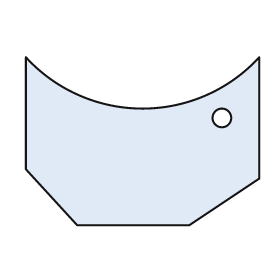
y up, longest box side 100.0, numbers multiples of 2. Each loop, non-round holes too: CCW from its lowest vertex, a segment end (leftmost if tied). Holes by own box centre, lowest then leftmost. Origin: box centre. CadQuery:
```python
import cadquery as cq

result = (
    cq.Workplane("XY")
    .moveTo(-28.0, -36.0)
    .lineTo(20.0, -36.0)
    .lineTo(50.0, -16.0)
    .lineTo(50.0, 36.0)
    .threePointArc((0.0, 14.0), (-50.0, 36.0))
    .lineTo(-50.0, -12.0)
    .close()
    .moveTo(34.0, 10.0)
    .circle(4.0)
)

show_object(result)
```